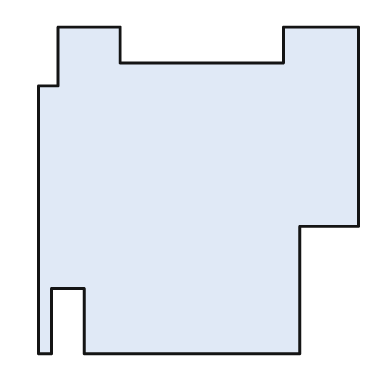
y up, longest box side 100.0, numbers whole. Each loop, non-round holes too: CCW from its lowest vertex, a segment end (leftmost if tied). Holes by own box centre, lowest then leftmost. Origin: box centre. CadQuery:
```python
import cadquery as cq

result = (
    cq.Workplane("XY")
    .moveTo(-49.0, -50.0)
    .lineTo(-45.0, -50.0)
    .lineTo(-45.0, -30.0)
    .lineTo(-35.0, -30.0)
    .lineTo(-35.0, -50.0)
    .lineTo(31.0, -50.0)
    .lineTo(31.0, -11.0)
    .lineTo(49.0, -11.0)
    .lineTo(49.0, 50.0)
    .lineTo(26.0, 50.0)
    .lineTo(26.0, 39.0)
    .lineTo(-24.0, 39.0)
    .lineTo(-24.0, 50.0)
    .lineTo(-43.0, 50.0)
    .lineTo(-43.0, 32.0)
    .lineTo(-49.0, 32.0)
    .close()
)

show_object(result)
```